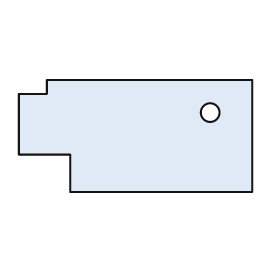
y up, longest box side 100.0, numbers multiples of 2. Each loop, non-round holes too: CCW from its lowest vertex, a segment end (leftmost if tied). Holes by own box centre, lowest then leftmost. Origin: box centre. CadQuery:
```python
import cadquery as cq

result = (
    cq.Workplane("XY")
    .moveTo(-28.0, -24.0)
    .lineTo(50.0, -24.0)
    .lineTo(50.0, 24.0)
    .lineTo(-38.0, 24.0)
    .lineTo(-38.0, 18.0)
    .lineTo(-50.0, 18.0)
    .lineTo(-50.0, -8.0)
    .lineTo(-28.0, -8.0)
    .close()
    .moveTo(32.0, 10.0)
    .circle(4.0)
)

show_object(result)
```